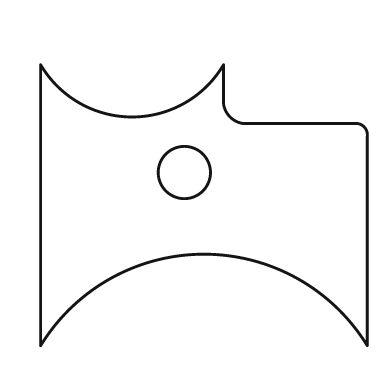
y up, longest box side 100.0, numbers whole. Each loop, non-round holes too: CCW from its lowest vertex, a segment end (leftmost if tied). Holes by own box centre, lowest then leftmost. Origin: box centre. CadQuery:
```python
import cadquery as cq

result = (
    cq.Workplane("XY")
    .moveTo(-50.0, -43.0)
    .threePointArc((0.0, -15.0), (50.0, -43.0))
    .lineTo(50.0, 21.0)
    .threePointArc((49.0, 24.0), (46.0, 25.0))
    .lineTo(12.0, 25.0)
    .threePointArc((8.0, 27.0), (6.0, 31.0))
    .lineTo(6.0, 43.0)
    .threePointArc((-22.0, 27.0), (-50.0, 43.0))
    .close()
    .moveTo(-6.0, 10.0)
    .circle(8.0)
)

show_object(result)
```